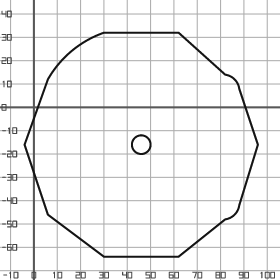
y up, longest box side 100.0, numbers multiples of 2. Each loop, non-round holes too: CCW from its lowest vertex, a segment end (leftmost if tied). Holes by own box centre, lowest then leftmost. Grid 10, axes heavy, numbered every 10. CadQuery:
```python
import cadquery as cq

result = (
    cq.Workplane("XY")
    .moveTo(30.0, -64.0)
    .lineTo(62.0, -64.0)
    .lineTo(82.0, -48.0)
    .threePointArc((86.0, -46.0), (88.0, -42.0))
    .lineTo(96.0, -16.0)
    .lineTo(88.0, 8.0)
    .threePointArc((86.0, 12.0), (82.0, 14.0))
    .lineTo(62.0, 32.0)
    .lineTo(30.0, 32.0)
    .threePointArc((16.0, 24.0), (6.0, 12.0))
    .lineTo(-4.0, -16.0)
    .lineTo(6.0, -46.0)
    .close()
    .moveTo(46.0, -16.0)
    .circle(4.0)
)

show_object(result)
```